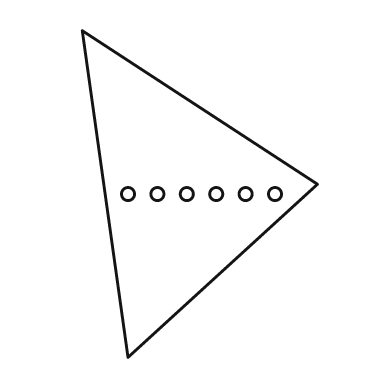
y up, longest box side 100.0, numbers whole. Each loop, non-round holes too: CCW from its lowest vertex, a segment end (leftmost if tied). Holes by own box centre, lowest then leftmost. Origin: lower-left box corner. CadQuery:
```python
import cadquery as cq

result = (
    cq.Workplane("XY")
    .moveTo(14.0, 0.0)
    .lineTo(72.0, 53.0)
    .lineTo(0.0, 100.0)
    .close()
    .moveTo(14.0, 50.0)
    .circle(2.0)
    .moveTo(23.0, 50.0)
    .circle(2.0)
    .moveTo(32.0, 50.0)
    .circle(2.0)
    .moveTo(41.0, 50.0)
    .circle(2.0)
    .moveTo(50.0, 50.0)
    .circle(2.0)
    .moveTo(59.0, 50.0)
    .circle(2.0)
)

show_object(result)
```